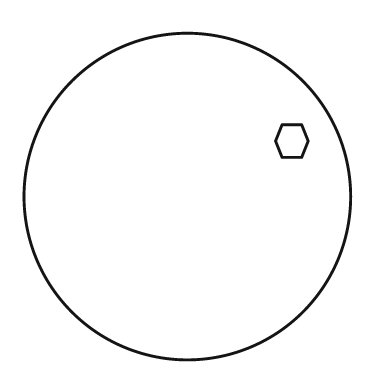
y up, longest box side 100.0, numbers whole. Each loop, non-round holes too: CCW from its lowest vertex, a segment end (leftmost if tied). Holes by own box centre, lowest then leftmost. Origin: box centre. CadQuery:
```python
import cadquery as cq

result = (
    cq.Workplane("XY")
    .moveTo(0.0, 0.0)
    .circle(50.0)
    .moveTo(29.0, 12.0)
    .lineTo(35.0, 12.0)
    .lineTo(37.0, 17.0)
    .lineTo(35.0, 22.0)
    .lineTo(29.0, 22.0)
    .lineTo(27.0, 17.0)
    .close()
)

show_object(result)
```